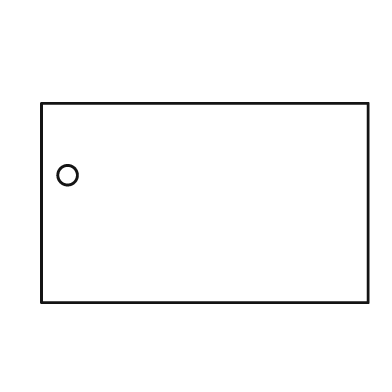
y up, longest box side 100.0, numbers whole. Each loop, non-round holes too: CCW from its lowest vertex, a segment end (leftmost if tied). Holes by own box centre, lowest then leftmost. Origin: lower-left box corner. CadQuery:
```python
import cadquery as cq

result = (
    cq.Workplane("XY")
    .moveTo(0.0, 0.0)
    .lineTo(100.0, 0.0)
    .lineTo(100.0, 61.0)
    .lineTo(0.0, 61.0)
    .close()
    .moveTo(8.0, 39.0)
    .circle(3.0)
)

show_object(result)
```